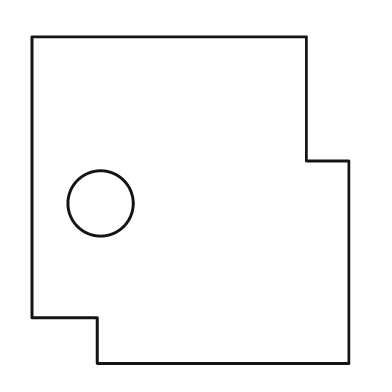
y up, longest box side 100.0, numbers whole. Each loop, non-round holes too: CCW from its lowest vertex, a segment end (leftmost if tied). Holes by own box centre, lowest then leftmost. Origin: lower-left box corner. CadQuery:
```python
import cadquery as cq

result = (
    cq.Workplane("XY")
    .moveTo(20.0, 0.0)
    .lineTo(97.0, 0.0)
    .lineTo(97.0, 62.0)
    .lineTo(84.0, 62.0)
    .lineTo(84.0, 100.0)
    .lineTo(0.0, 100.0)
    .lineTo(0.0, 14.0)
    .lineTo(20.0, 14.0)
    .close()
    .moveTo(21.0, 49.0)
    .circle(10.0)
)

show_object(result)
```